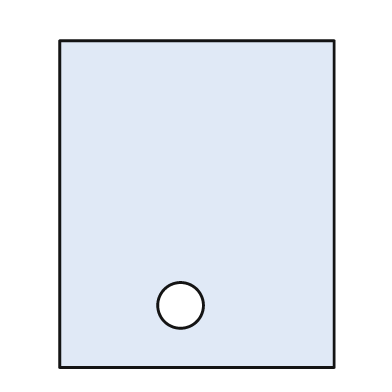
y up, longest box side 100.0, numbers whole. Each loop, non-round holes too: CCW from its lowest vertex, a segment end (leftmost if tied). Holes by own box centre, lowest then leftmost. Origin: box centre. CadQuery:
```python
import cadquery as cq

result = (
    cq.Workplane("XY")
    .moveTo(-42.0, -50.0)
    .lineTo(42.0, -50.0)
    .lineTo(42.0, 50.0)
    .lineTo(-42.0, 50.0)
    .close()
    .moveTo(-5.0, -31.0)
    .circle(7.0)
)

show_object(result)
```